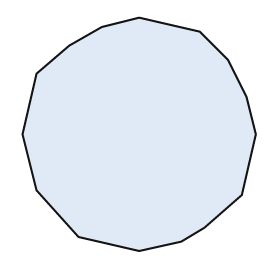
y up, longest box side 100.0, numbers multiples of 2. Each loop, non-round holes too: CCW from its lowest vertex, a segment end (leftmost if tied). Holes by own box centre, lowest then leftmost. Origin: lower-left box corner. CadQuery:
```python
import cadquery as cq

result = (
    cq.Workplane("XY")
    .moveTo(50.0, 0.0)
    .lineTo(68.0, 4.0)
    .lineTo(78.0, 10.0)
    .lineTo(94.0, 24.0)
    .lineTo(100.0, 50.0)
    .lineTo(96.0, 66.0)
    .lineTo(88.0, 82.0)
    .lineTo(76.0, 94.0)
    .lineTo(50.0, 100.0)
    .lineTo(34.0, 96.0)
    .lineTo(20.0, 88.0)
    .lineTo(6.0, 76.0)
    .lineTo(0.0, 50.0)
    .lineTo(6.0, 26.0)
    .lineTo(24.0, 6.0)
    .close()
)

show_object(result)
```